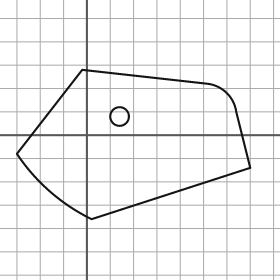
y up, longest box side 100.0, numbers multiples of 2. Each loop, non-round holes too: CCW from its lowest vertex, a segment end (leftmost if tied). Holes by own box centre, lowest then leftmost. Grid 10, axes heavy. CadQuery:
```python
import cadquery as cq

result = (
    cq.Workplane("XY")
    .moveTo(2.0, -36.0)
    .lineTo(70.0, -14.0)
    .lineTo(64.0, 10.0)
    .threePointArc((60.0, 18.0), (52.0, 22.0))
    .lineTo(-2.0, 28.0)
    .lineTo(-30.0, -8.0)
    .threePointArc((-16.0, -24.0), (2.0, -36.0))
    .close()
    .moveTo(14.0, 8.0)
    .circle(4.0)
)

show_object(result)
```